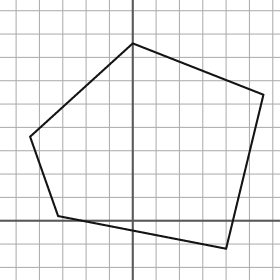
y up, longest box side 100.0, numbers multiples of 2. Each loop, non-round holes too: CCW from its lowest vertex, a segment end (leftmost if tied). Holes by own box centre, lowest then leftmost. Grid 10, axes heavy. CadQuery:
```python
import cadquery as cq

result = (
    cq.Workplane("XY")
    .moveTo(40.0, -12.0)
    .lineTo(56.0, 54.0)
    .lineTo(0.0, 76.0)
    .lineTo(-44.0, 36.0)
    .lineTo(-32.0, 2.0)
    .close()
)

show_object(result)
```